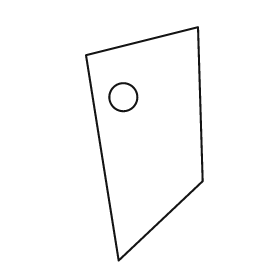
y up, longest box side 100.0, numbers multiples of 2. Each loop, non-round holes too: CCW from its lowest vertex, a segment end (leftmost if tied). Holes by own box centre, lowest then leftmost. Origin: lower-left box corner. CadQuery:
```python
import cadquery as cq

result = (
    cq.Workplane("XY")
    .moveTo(14.0, 0.0)
    .lineTo(50.0, 34.0)
    .lineTo(48.0, 100.0)
    .lineTo(0.0, 88.0)
    .close()
    .moveTo(16.0, 70.0)
    .circle(6.0)
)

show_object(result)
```